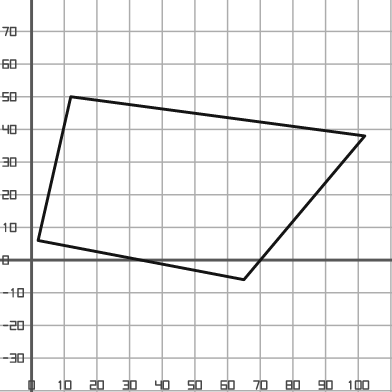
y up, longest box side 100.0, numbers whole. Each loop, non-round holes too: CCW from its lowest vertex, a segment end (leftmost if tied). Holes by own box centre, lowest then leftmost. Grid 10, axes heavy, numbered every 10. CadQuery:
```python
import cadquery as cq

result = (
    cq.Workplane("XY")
    .moveTo(65.0, -6.0)
    .lineTo(102.0, 38.0)
    .lineTo(12.0, 50.0)
    .lineTo(2.0, 6.0)
    .close()
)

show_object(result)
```